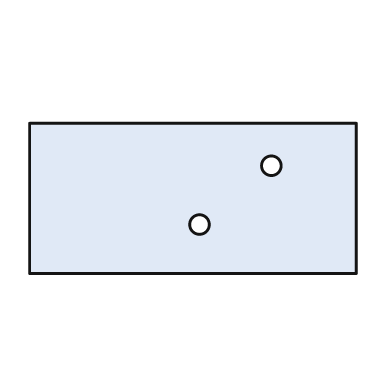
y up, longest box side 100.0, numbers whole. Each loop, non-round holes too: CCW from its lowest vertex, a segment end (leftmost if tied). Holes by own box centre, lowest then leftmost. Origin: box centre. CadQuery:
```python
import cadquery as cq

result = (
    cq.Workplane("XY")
    .moveTo(-50.0, -23.0)
    .lineTo(50.0, -23.0)
    .lineTo(50.0, 23.0)
    .lineTo(-50.0, 23.0)
    .close()
    .moveTo(2.0, -8.0)
    .circle(3.0)
    .moveTo(24.0, 10.0)
    .circle(3.0)
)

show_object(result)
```